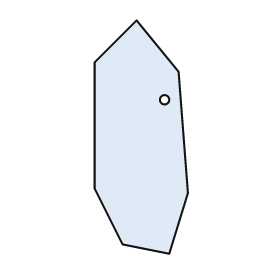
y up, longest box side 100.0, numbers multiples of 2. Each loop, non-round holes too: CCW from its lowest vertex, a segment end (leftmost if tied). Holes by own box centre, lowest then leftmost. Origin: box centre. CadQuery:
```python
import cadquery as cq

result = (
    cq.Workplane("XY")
    .moveTo(12.0, -50.0)
    .lineTo(20.0, -24.0)
    .lineTo(16.0, 28.0)
    .lineTo(-2.0, 50.0)
    .lineTo(-20.0, 32.0)
    .lineTo(-20.0, -22.0)
    .lineTo(-8.0, -46.0)
    .close()
    .moveTo(10.0, 16.0)
    .circle(2.0)
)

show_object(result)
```